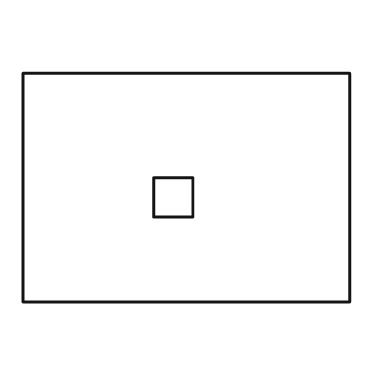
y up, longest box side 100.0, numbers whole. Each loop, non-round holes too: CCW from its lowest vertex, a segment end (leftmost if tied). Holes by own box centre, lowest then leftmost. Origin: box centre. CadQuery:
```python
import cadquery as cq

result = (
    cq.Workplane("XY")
    .moveTo(-50.0, -35.0)
    .lineTo(50.0, -35.0)
    .lineTo(50.0, 35.0)
    .lineTo(-50.0, 35.0)
    .close()
    .moveTo(-10.0, -9.0)
    .lineTo(2.0, -9.0)
    .lineTo(2.0, 3.0)
    .lineTo(-10.0, 3.0)
    .close()
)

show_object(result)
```